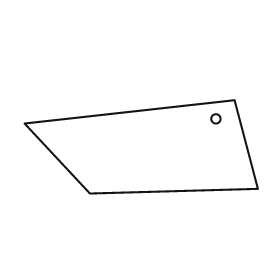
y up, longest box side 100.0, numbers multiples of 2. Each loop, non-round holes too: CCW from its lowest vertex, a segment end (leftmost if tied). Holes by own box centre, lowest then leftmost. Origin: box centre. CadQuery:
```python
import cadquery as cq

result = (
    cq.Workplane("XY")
    .moveTo(-22.0, -20.0)
    .lineTo(50.0, -18.0)
    .lineTo(40.0, 20.0)
    .lineTo(-50.0, 10.0)
    .close()
    .moveTo(32.0, 12.0)
    .circle(2.0)
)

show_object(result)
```